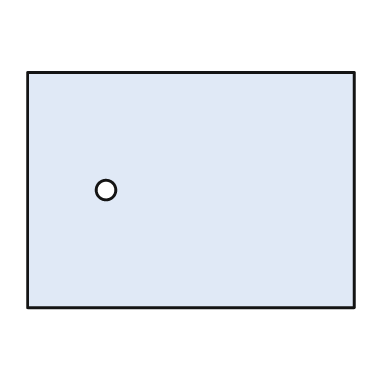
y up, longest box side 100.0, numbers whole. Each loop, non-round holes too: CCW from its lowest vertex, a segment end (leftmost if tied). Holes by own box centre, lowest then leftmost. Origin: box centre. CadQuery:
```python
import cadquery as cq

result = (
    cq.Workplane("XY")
    .moveTo(-50.0, -36.0)
    .lineTo(50.0, -36.0)
    .lineTo(50.0, 36.0)
    .lineTo(-50.0, 36.0)
    .close()
    .moveTo(-26.0, 0.0)
    .circle(3.0)
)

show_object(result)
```